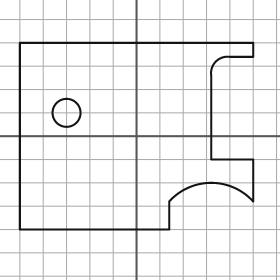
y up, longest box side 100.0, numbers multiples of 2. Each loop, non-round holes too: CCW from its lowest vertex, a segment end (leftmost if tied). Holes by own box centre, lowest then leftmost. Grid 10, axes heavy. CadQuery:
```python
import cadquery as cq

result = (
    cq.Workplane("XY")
    .moveTo(-50.0, -40.0)
    .lineTo(14.0, -40.0)
    .lineTo(14.0, -28.0)
    .threePointArc((32.0, -20.0), (50.0, -28.0))
    .lineTo(50.0, -10.0)
    .lineTo(32.0, -10.0)
    .lineTo(32.0, 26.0)
    .threePointArc((34.0, 32.0), (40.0, 34.0))
    .lineTo(50.0, 34.0)
    .lineTo(50.0, 40.0)
    .lineTo(-50.0, 40.0)
    .close()
    .moveTo(-30.0, 10.0)
    .circle(6.0)
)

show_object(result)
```